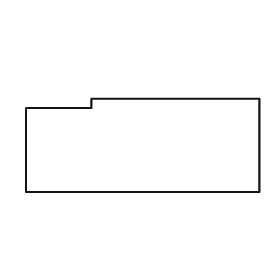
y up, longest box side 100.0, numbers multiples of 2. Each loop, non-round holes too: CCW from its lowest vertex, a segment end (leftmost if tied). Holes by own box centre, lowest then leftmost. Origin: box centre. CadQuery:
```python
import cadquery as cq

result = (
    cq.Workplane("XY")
    .moveTo(-50.0, -20.0)
    .lineTo(50.0, -20.0)
    .lineTo(50.0, 20.0)
    .lineTo(-22.0, 20.0)
    .lineTo(-22.0, 16.0)
    .lineTo(-50.0, 16.0)
    .close()
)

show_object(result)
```